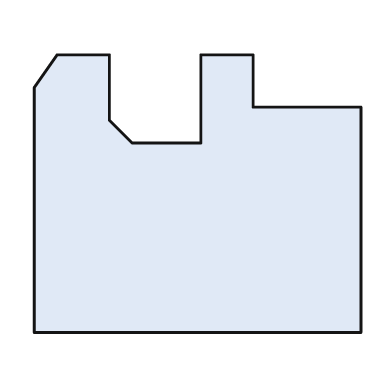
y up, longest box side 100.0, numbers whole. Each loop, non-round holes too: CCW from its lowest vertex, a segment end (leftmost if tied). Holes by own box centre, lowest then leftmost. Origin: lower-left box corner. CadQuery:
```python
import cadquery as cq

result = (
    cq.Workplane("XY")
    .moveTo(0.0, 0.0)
    .lineTo(100.0, 0.0)
    .lineTo(100.0, 69.0)
    .lineTo(67.0, 69.0)
    .lineTo(67.0, 85.0)
    .lineTo(51.0, 85.0)
    .lineTo(51.0, 58.0)
    .lineTo(30.0, 58.0)
    .lineTo(23.0, 65.0)
    .lineTo(23.0, 85.0)
    .lineTo(7.0, 85.0)
    .lineTo(0.0, 75.0)
    .close()
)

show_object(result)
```